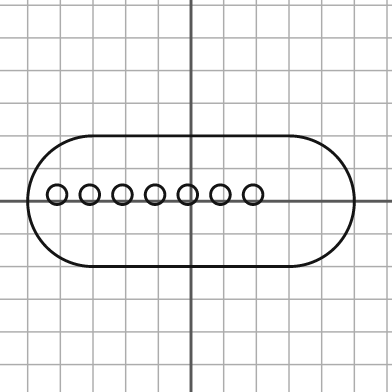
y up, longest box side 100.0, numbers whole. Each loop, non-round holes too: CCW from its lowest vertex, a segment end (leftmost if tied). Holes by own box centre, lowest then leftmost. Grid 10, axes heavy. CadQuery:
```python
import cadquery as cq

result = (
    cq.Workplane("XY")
    .moveTo(-30.0, -20.0)
    .lineTo(30.0, -20.0)
    .threePointArc((50.0, 0.0), (30.0, 20.0))
    .lineTo(-30.0, 20.0)
    .threePointArc((-50.0, 0.0), (-30.0, -20.0))
    .close()
    .moveTo(-41.0, 2.0)
    .circle(3.0)
    .moveTo(-31.0, 2.0)
    .circle(3.0)
    .moveTo(-21.0, 2.0)
    .circle(3.0)
    .moveTo(-11.0, 2.0)
    .circle(3.0)
    .moveTo(-1.0, 2.0)
    .circle(3.0)
    .moveTo(9.0, 2.0)
    .circle(3.0)
    .moveTo(19.0, 2.0)
    .circle(3.0)
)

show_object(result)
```